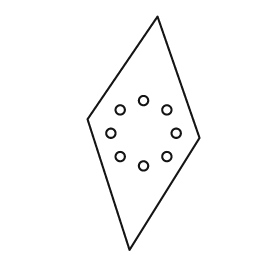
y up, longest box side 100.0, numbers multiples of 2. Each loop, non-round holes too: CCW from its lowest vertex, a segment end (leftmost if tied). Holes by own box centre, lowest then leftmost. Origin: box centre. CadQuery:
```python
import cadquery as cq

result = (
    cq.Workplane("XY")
    .moveTo(-6.0, -50.0)
    .lineTo(24.0, -2.0)
    .lineTo(6.0, 50.0)
    .lineTo(-24.0, 6.0)
    .close()
    .moveTo(0.0, -14.0)
    .circle(2.0)
    .moveTo(-10.0, -10.0)
    .circle(2.0)
    .moveTo(10.0, -10.0)
    .circle(2.0)
    .moveTo(-14.0, 0.0)
    .circle(2.0)
    .moveTo(14.0, 0.0)
    .circle(2.0)
    .moveTo(-10.0, 10.0)
    .circle(2.0)
    .moveTo(10.0, 10.0)
    .circle(2.0)
    .moveTo(0.0, 14.0)
    .circle(2.0)
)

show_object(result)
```